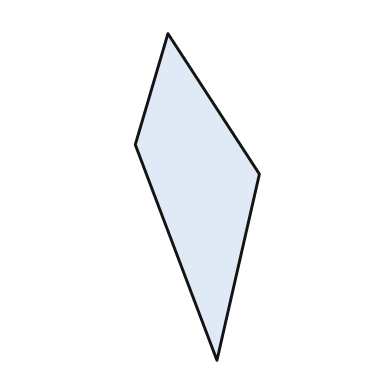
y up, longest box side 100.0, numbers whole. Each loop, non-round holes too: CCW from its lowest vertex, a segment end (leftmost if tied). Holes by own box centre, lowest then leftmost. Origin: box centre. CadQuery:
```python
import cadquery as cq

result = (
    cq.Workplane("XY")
    .moveTo(6.0, -50.0)
    .lineTo(19.0, 7.0)
    .lineTo(-9.0, 50.0)
    .lineTo(-19.0, 16.0)
    .close()
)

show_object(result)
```